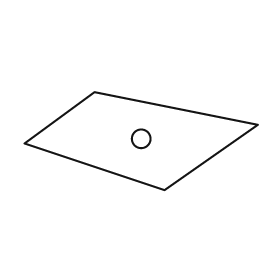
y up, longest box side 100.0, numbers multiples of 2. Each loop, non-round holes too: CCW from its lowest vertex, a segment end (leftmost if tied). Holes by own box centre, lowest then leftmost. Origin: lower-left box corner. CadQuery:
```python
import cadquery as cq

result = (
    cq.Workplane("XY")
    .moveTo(60.0, 0.0)
    .lineTo(100.0, 28.0)
    .lineTo(30.0, 42.0)
    .lineTo(0.0, 20.0)
    .close()
    .moveTo(50.0, 22.0)
    .circle(4.0)
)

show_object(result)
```